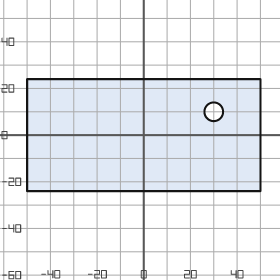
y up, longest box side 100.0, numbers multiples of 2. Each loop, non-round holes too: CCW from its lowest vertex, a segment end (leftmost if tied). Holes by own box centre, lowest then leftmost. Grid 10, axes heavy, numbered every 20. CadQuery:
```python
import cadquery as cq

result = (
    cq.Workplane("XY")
    .moveTo(-50.0, -24.0)
    .lineTo(50.0, -24.0)
    .lineTo(50.0, 24.0)
    .lineTo(-50.0, 24.0)
    .close()
    .moveTo(30.0, 10.0)
    .circle(4.0)
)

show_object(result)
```